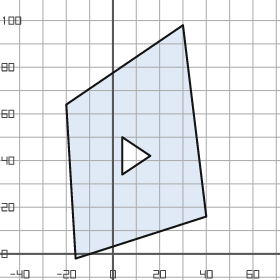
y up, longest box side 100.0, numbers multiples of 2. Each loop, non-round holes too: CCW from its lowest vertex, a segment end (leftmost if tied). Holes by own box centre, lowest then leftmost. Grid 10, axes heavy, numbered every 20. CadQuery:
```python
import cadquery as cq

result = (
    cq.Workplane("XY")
    .moveTo(-16.0, -2.0)
    .lineTo(40.0, 16.0)
    .lineTo(30.0, 98.0)
    .lineTo(-20.0, 64.0)
    .close()
    .moveTo(4.0, 34.0)
    .lineTo(16.0, 42.0)
    .lineTo(4.0, 50.0)
    .close()
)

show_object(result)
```